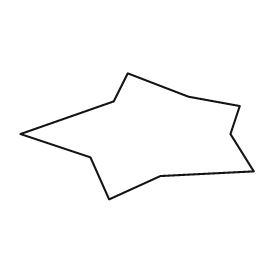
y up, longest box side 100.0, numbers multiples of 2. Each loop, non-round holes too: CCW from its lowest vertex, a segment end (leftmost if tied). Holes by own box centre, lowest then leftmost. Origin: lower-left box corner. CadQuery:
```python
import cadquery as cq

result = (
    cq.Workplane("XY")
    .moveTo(38.0, 0.0)
    .lineTo(60.0, 10.0)
    .lineTo(100.0, 12.0)
    .lineTo(90.0, 28.0)
    .lineTo(94.0, 40.0)
    .lineTo(72.0, 44.0)
    .lineTo(46.0, 54.0)
    .lineTo(40.0, 42.0)
    .lineTo(0.0, 28.0)
    .lineTo(30.0, 18.0)
    .close()
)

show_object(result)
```